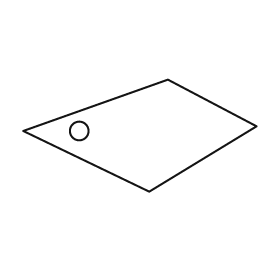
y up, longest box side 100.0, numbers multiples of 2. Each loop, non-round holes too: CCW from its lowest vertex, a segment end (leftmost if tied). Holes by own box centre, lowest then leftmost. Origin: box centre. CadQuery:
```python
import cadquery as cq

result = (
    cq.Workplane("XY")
    .moveTo(4.0, -24.0)
    .lineTo(50.0, 4.0)
    .lineTo(12.0, 24.0)
    .lineTo(-50.0, 2.0)
    .close()
    .moveTo(-26.0, 2.0)
    .circle(4.0)
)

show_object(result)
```